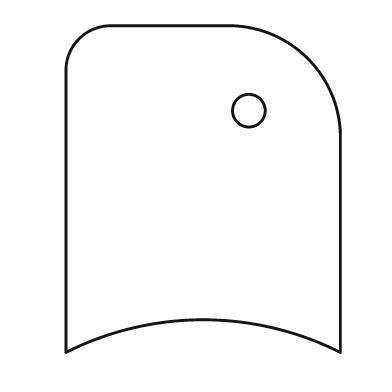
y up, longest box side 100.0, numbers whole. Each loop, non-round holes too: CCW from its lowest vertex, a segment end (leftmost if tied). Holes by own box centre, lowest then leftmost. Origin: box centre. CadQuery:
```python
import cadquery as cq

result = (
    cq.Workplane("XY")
    .moveTo(-42.0, -50.0)
    .threePointArc((0.0, -40.0), (42.0, -50.0))
    .lineTo(42.0, 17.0)
    .threePointArc((32.0, 40.0), (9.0, 50.0))
    .lineTo(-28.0, 50.0)
    .threePointArc((-38.0, 46.0), (-42.0, 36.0))
    .close()
    .moveTo(14.0, 24.0)
    .circle(5.0)
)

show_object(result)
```